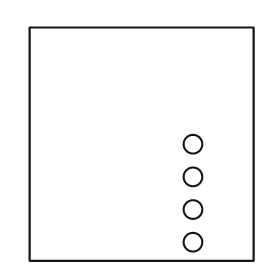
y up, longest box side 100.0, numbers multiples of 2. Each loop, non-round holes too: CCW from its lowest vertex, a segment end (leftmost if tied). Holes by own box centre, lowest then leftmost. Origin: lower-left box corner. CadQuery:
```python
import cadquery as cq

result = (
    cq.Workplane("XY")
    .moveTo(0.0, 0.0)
    .lineTo(96.0, 0.0)
    .lineTo(96.0, 100.0)
    .lineTo(0.0, 100.0)
    .close()
    .moveTo(70.0, 8.0)
    .circle(4.0)
    .moveTo(70.0, 22.0)
    .circle(4.0)
    .moveTo(70.0, 36.0)
    .circle(4.0)
    .moveTo(70.0, 50.0)
    .circle(4.0)
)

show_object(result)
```